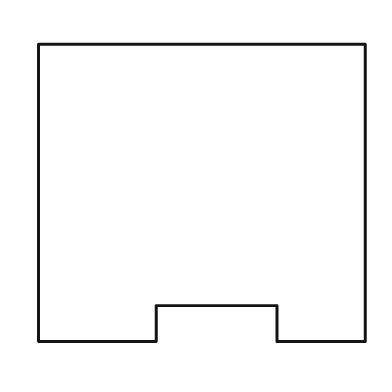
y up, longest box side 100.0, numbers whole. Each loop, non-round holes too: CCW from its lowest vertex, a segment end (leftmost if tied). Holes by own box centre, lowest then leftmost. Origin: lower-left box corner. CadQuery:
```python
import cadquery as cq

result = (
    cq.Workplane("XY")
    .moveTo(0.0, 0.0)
    .lineTo(36.0, 0.0)
    .lineTo(36.0, 11.0)
    .lineTo(73.0, 11.0)
    .lineTo(73.0, 0.0)
    .lineTo(100.0, 0.0)
    .lineTo(100.0, 91.0)
    .lineTo(0.0, 91.0)
    .close()
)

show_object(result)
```